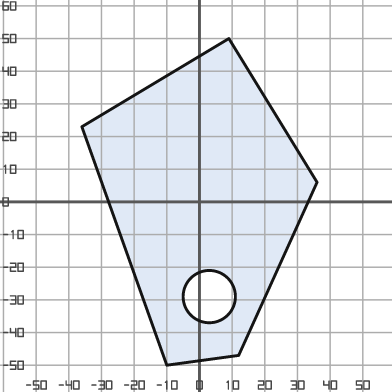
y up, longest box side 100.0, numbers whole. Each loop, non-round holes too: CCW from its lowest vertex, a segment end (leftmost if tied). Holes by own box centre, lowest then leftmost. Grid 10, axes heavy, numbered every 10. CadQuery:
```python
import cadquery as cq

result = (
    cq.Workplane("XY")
    .moveTo(-10.0, -50.0)
    .lineTo(12.0, -47.0)
    .lineTo(36.0, 6.0)
    .lineTo(9.0, 50.0)
    .lineTo(-36.0, 23.0)
    .close()
    .moveTo(3.0, -29.0)
    .circle(8.0)
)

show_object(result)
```